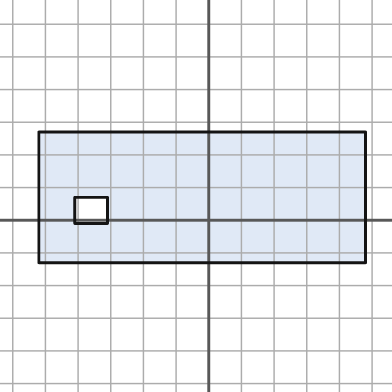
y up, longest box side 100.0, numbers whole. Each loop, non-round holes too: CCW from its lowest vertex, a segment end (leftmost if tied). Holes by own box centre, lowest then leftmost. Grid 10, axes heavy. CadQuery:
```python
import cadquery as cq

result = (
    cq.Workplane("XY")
    .moveTo(-52.0, -13.0)
    .lineTo(48.0, -13.0)
    .lineTo(48.0, 27.0)
    .lineTo(-52.0, 27.0)
    .close()
    .moveTo(-41.0, -1.0)
    .lineTo(-31.0, -1.0)
    .lineTo(-31.0, 7.0)
    .lineTo(-41.0, 7.0)
    .close()
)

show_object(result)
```